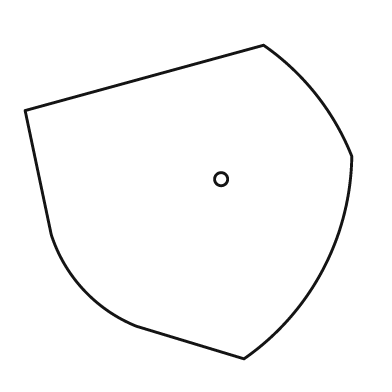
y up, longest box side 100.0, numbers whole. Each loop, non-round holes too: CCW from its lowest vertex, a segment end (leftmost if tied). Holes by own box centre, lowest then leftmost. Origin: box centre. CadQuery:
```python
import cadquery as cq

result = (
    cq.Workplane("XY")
    .moveTo(17.0, -48.0)
    .threePointArc((41.0, -21.0), (50.0, 14.0))
    .threePointArc((39.0, 33.0), (23.0, 48.0))
    .lineTo(-50.0, 28.0)
    .lineTo(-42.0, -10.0)
    .threePointArc((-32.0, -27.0), (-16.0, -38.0))
    .close()
    .moveTo(10.0, 7.0)
    .circle(2.0)
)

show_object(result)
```